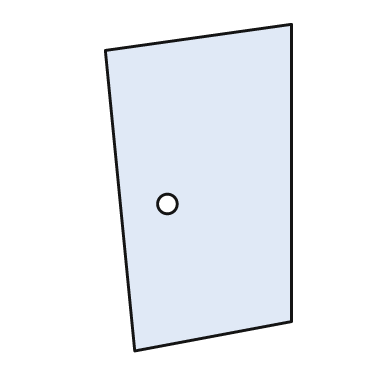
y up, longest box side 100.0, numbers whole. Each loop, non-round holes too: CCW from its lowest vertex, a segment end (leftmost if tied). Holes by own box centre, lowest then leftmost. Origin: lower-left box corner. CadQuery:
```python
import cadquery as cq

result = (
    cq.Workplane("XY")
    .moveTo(9.0, 0.0)
    .lineTo(57.0, 9.0)
    .lineTo(57.0, 100.0)
    .lineTo(0.0, 92.0)
    .close()
    .moveTo(19.0, 45.0)
    .circle(3.0)
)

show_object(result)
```